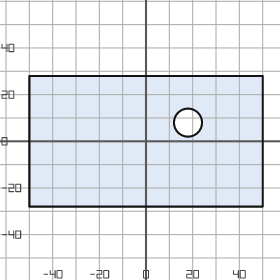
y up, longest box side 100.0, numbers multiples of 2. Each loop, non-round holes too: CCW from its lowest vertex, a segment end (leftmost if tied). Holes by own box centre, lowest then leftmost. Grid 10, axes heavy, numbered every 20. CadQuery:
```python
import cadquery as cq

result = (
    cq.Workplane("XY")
    .moveTo(-50.0, -28.0)
    .lineTo(50.0, -28.0)
    .lineTo(50.0, 28.0)
    .lineTo(-50.0, 28.0)
    .close()
    .moveTo(18.0, 8.0)
    .circle(6.0)
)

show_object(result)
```